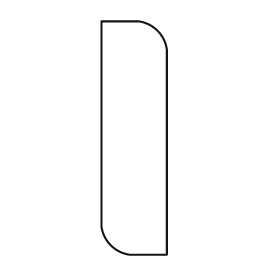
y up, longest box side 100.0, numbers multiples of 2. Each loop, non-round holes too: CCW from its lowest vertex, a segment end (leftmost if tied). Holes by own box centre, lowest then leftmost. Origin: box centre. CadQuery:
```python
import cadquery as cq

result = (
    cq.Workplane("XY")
    .moveTo(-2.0, -50.0)
    .lineTo(14.0, -50.0)
    .lineTo(14.0, 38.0)
    .threePointArc((10.0, 46.0), (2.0, 50.0))
    .lineTo(-14.0, 50.0)
    .lineTo(-14.0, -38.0)
    .threePointArc((-10.0, -46.0), (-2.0, -50.0))
    .close()
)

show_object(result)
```